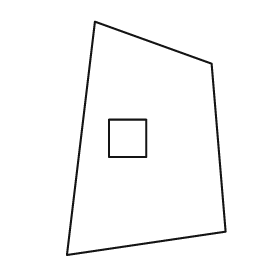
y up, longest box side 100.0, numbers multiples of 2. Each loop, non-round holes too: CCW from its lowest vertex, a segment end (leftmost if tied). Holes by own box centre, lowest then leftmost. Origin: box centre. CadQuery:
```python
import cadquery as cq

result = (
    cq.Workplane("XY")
    .moveTo(-34.0, -50.0)
    .lineTo(34.0, -40.0)
    .lineTo(28.0, 32.0)
    .lineTo(-22.0, 50.0)
    .close()
    .moveTo(-16.0, -8.0)
    .lineTo(0.0, -8.0)
    .lineTo(0.0, 8.0)
    .lineTo(-16.0, 8.0)
    .close()
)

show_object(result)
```